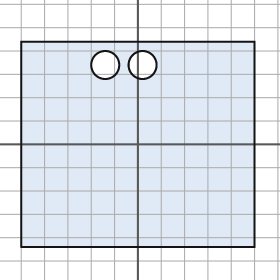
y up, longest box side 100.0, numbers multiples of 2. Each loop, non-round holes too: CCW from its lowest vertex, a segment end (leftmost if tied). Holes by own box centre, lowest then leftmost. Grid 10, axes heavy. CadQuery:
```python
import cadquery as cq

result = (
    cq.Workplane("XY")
    .moveTo(-50.0, -44.0)
    .lineTo(50.0, -44.0)
    .lineTo(50.0, 44.0)
    .lineTo(-50.0, 44.0)
    .close()
    .moveTo(-14.0, 34.0)
    .circle(6.0)
    .moveTo(2.0, 34.0)
    .circle(6.0)
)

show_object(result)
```